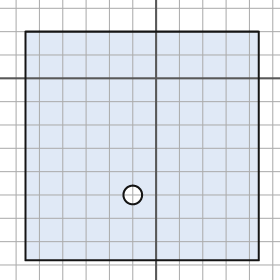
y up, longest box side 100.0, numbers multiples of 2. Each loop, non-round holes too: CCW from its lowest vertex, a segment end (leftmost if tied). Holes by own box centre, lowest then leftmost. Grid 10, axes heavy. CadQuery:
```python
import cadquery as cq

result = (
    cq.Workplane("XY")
    .moveTo(-56.0, -78.0)
    .lineTo(44.0, -78.0)
    .lineTo(44.0, 20.0)
    .lineTo(-56.0, 20.0)
    .close()
    .moveTo(-10.0, -50.0)
    .circle(4.0)
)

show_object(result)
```